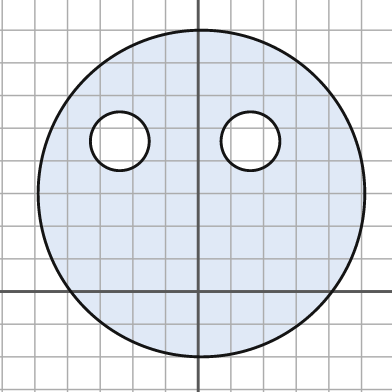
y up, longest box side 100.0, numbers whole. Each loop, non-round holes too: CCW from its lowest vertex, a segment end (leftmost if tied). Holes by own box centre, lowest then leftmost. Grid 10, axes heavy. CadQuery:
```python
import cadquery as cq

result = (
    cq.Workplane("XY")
    .moveTo(1.0, 30.0)
    .circle(50.0)
    .moveTo(-24.0, 46.0)
    .circle(9.0)
    .moveTo(16.0, 46.0)
    .circle(9.0)
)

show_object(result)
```